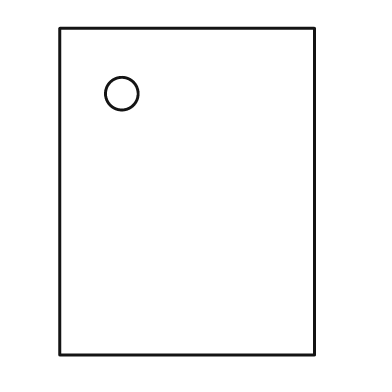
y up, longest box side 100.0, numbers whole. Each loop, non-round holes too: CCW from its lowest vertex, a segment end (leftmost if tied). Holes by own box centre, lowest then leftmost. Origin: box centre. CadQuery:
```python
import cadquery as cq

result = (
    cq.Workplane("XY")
    .moveTo(-39.0, -50.0)
    .lineTo(39.0, -50.0)
    .lineTo(39.0, 50.0)
    .lineTo(-39.0, 50.0)
    .close()
    .moveTo(-20.0, 30.0)
    .circle(5.0)
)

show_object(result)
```